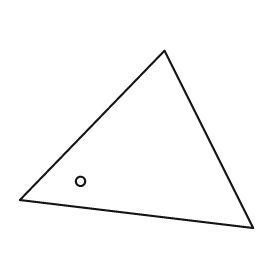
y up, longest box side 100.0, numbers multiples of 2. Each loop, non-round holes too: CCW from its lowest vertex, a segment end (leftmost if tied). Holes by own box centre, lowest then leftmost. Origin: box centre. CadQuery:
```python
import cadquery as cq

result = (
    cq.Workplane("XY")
    .moveTo(50.0, -38.0)
    .lineTo(12.0, 38.0)
    .lineTo(-50.0, -26.0)
    .close()
    .moveTo(-24.0, -18.0)
    .circle(2.0)
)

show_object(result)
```